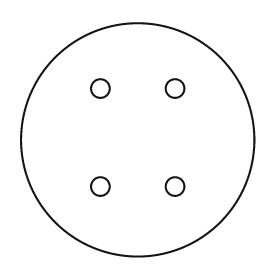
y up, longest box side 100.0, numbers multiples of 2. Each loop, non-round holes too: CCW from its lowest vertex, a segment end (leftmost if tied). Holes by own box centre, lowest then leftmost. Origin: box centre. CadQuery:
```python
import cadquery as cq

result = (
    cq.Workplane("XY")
    .moveTo(0.0, 0.0)
    .circle(50.0)
    .moveTo(-16.0, -20.0)
    .circle(4.0)
    .moveTo(16.0, -20.0)
    .circle(4.0)
    .moveTo(-16.0, 22.0)
    .circle(4.0)
    .moveTo(16.0, 22.0)
    .circle(4.0)
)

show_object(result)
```